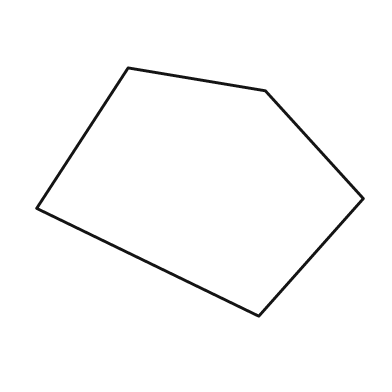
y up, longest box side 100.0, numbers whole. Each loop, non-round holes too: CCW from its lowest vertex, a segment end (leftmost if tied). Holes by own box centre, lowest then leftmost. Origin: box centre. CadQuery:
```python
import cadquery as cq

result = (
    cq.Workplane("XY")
    .moveTo(18.0, -38.0)
    .lineTo(50.0, -2.0)
    .lineTo(20.0, 31.0)
    .lineTo(-22.0, 38.0)
    .lineTo(-50.0, -5.0)
    .close()
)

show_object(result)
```